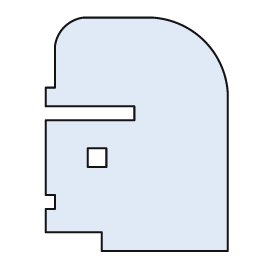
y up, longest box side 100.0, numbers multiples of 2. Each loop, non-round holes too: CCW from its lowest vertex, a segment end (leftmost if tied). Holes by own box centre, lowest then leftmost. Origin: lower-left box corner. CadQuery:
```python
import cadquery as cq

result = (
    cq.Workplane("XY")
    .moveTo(24.0, 0.0)
    .lineTo(78.0, 0.0)
    .lineTo(78.0, 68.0)
    .threePointArc((68.0, 90.0), (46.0, 100.0))
    .lineTo(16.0, 100.0)
    .threePointArc((8.0, 96.0), (4.0, 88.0))
    .lineTo(4.0, 70.0)
    .lineTo(0.0, 70.0)
    .lineTo(0.0, 62.0)
    .lineTo(38.0, 62.0)
    .lineTo(38.0, 56.0)
    .lineTo(0.0, 56.0)
    .lineTo(0.0, 24.0)
    .lineTo(4.0, 24.0)
    .lineTo(4.0, 18.0)
    .lineTo(0.0, 18.0)
    .lineTo(0.0, 8.0)
    .lineTo(24.0, 8.0)
    .close()
    .moveTo(18.0, 36.0)
    .lineTo(26.0, 36.0)
    .lineTo(26.0, 44.0)
    .lineTo(18.0, 44.0)
    .close()
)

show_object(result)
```